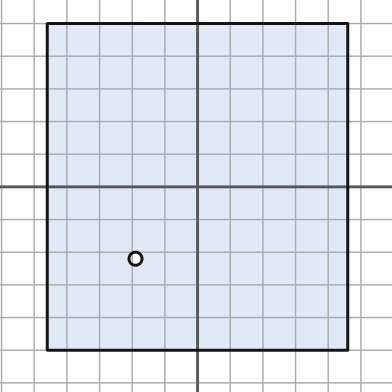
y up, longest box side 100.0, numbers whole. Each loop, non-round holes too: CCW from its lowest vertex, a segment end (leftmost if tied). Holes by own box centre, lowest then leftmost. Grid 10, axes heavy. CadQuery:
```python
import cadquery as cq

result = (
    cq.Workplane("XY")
    .moveTo(-46.0, -50.0)
    .lineTo(46.0, -50.0)
    .lineTo(46.0, 50.0)
    .lineTo(-46.0, 50.0)
    .close()
    .moveTo(-19.0, -22.0)
    .circle(2.0)
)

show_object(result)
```